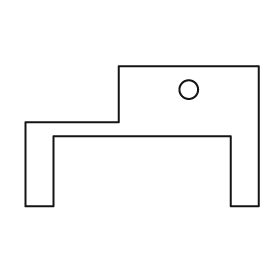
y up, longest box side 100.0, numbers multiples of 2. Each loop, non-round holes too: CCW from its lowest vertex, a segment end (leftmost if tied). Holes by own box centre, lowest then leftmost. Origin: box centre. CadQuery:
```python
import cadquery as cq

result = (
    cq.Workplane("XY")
    .moveTo(-50.0, -30.0)
    .lineTo(-38.0, -30.0)
    .lineTo(-38.0, 0.0)
    .lineTo(38.0, 0.0)
    .lineTo(38.0, -30.0)
    .lineTo(50.0, -30.0)
    .lineTo(50.0, 30.0)
    .lineTo(-10.0, 30.0)
    .lineTo(-10.0, 6.0)
    .lineTo(-50.0, 6.0)
    .close()
    .moveTo(20.0, 20.0)
    .circle(4.0)
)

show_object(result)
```